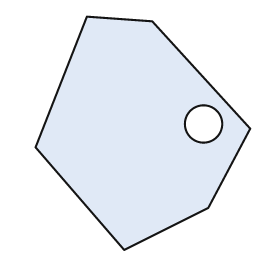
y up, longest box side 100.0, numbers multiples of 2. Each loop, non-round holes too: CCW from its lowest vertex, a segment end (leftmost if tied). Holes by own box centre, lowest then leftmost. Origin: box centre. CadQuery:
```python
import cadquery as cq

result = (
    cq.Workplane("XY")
    .moveTo(-8.0, -50.0)
    .lineTo(28.0, -32.0)
    .lineTo(46.0, 2.0)
    .lineTo(4.0, 48.0)
    .lineTo(-24.0, 50.0)
    .lineTo(-46.0, -6.0)
    .close()
    .moveTo(26.0, 4.0)
    .circle(8.0)
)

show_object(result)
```